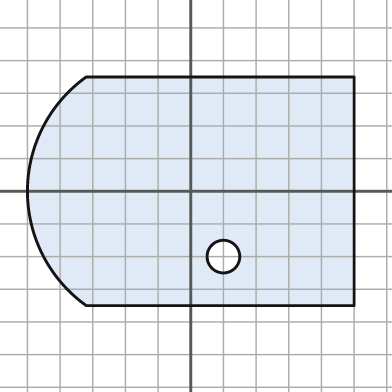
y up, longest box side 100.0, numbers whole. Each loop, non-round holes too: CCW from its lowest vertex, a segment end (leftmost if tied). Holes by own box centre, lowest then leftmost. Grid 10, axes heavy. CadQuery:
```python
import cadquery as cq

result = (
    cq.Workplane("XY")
    .moveTo(-32.0, -35.0)
    .lineTo(50.0, -35.0)
    .lineTo(50.0, 35.0)
    .lineTo(-32.0, 35.0)
    .threePointArc((-50.0, 0.0), (-32.0, -35.0))
    .close()
    .moveTo(10.0, -20.0)
    .circle(5.0)
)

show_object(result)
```